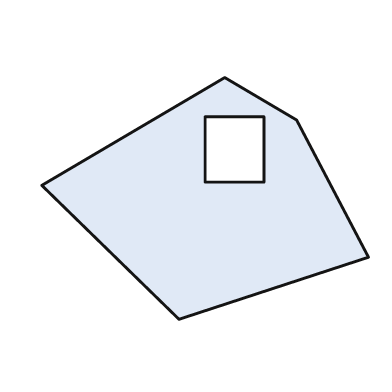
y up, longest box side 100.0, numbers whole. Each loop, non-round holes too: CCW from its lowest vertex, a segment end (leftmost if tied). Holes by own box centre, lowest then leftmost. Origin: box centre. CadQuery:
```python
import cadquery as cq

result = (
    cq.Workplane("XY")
    .moveTo(-8.0, -37.0)
    .lineTo(50.0, -18.0)
    .lineTo(28.0, 24.0)
    .lineTo(6.0, 37.0)
    .lineTo(-50.0, 4.0)
    .close()
    .moveTo(0.0, 5.0)
    .lineTo(18.0, 5.0)
    .lineTo(18.0, 25.0)
    .lineTo(0.0, 25.0)
    .close()
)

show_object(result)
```